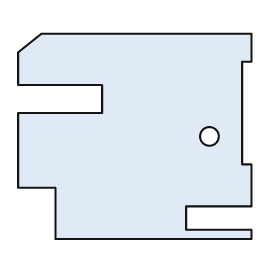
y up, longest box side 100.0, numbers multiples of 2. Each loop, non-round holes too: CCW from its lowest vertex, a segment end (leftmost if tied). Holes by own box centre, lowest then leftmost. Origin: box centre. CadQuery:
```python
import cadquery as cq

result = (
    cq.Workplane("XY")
    .moveTo(-34.0, -44.0)
    .lineTo(50.0, -44.0)
    .lineTo(50.0, -40.0)
    .lineTo(22.0, -40.0)
    .lineTo(22.0, -30.0)
    .lineTo(50.0, -30.0)
    .lineTo(50.0, -12.0)
    .lineTo(46.0, -12.0)
    .lineTo(46.0, 32.0)
    .lineTo(50.0, 32.0)
    .lineTo(50.0, 44.0)
    .lineTo(-40.0, 44.0)
    .lineTo(-50.0, 36.0)
    .lineTo(-50.0, 22.0)
    .lineTo(-14.0, 22.0)
    .lineTo(-14.0, 10.0)
    .lineTo(-50.0, 10.0)
    .lineTo(-50.0, -22.0)
    .lineTo(-34.0, -22.0)
    .close()
    .moveTo(32.0, 0.0)
    .circle(4.0)
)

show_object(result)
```